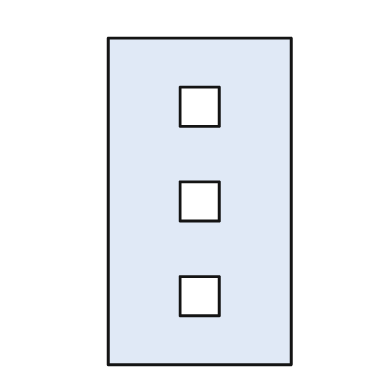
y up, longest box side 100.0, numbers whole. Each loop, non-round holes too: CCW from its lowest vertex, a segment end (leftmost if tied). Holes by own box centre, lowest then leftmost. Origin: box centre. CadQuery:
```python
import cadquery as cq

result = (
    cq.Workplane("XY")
    .moveTo(-28.0, -50.0)
    .lineTo(28.0, -50.0)
    .lineTo(28.0, 50.0)
    .lineTo(-28.0, 50.0)
    .close()
    .moveTo(-6.0, -35.0)
    .lineTo(6.0, -35.0)
    .lineTo(6.0, -23.0)
    .lineTo(-6.0, -23.0)
    .close()
    .moveTo(-6.0, -6.0)
    .lineTo(6.0, -6.0)
    .lineTo(6.0, 6.0)
    .lineTo(-6.0, 6.0)
    .close()
    .moveTo(-6.0, 23.0)
    .lineTo(6.0, 23.0)
    .lineTo(6.0, 35.0)
    .lineTo(-6.0, 35.0)
    .close()
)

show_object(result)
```